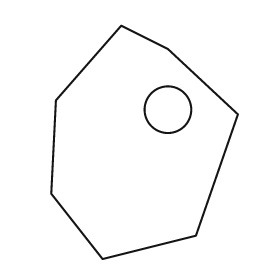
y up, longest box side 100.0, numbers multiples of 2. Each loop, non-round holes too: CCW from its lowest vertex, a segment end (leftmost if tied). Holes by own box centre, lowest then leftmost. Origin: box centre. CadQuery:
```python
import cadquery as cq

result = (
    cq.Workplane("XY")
    .moveTo(-18.0, -50.0)
    .lineTo(22.0, -40.0)
    .lineTo(40.0, 12.0)
    .lineTo(10.0, 40.0)
    .lineTo(-10.0, 50.0)
    .lineTo(-38.0, 18.0)
    .lineTo(-40.0, -22.0)
    .close()
    .moveTo(10.0, 14.0)
    .circle(10.0)
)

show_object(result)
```